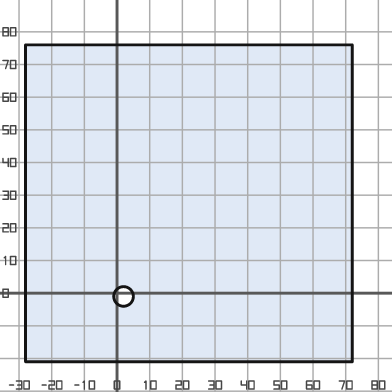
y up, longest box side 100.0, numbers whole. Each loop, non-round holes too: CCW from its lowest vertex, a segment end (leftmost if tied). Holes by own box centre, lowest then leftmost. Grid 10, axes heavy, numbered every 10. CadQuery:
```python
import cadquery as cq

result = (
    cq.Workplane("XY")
    .moveTo(-28.0, -21.0)
    .lineTo(72.0, -21.0)
    .lineTo(72.0, 76.0)
    .lineTo(-28.0, 76.0)
    .close()
    .moveTo(2.0, -1.0)
    .circle(3.0)
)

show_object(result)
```